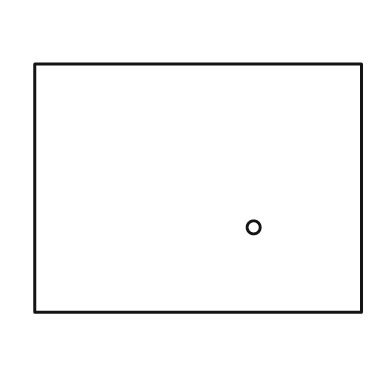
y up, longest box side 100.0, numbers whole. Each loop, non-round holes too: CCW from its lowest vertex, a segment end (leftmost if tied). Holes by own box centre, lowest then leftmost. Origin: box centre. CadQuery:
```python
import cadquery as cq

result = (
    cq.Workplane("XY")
    .moveTo(-50.0, -38.0)
    .lineTo(50.0, -38.0)
    .lineTo(50.0, 38.0)
    .lineTo(-50.0, 38.0)
    .close()
    .moveTo(17.0, -12.0)
    .circle(2.0)
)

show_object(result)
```